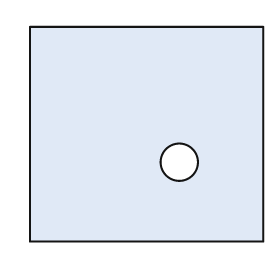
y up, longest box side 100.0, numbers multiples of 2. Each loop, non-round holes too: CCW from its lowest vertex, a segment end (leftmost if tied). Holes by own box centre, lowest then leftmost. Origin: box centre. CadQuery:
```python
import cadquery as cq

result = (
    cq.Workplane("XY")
    .moveTo(-50.0, -46.0)
    .lineTo(50.0, -46.0)
    .lineTo(50.0, 46.0)
    .lineTo(-50.0, 46.0)
    .close()
    .moveTo(14.0, -12.0)
    .circle(8.0)
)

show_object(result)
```